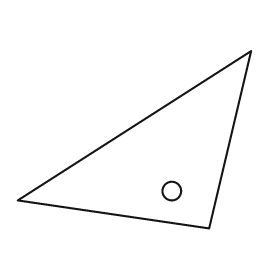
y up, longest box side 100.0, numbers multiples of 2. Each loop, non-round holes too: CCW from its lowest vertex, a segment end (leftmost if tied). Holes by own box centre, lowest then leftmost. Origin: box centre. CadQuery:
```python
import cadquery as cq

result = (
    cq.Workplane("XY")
    .moveTo(32.0, -38.0)
    .lineTo(50.0, 38.0)
    .lineTo(-50.0, -26.0)
    .close()
    .moveTo(16.0, -22.0)
    .circle(4.0)
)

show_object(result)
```